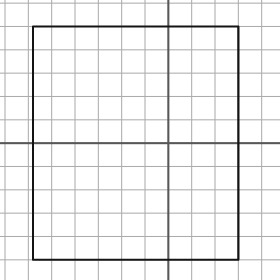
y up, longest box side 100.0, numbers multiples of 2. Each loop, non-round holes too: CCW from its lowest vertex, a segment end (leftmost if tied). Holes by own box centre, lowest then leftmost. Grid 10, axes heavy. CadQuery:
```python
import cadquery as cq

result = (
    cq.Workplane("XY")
    .moveTo(-58.0, -50.0)
    .lineTo(30.0, -50.0)
    .lineTo(30.0, 50.0)
    .lineTo(-58.0, 50.0)
    .close()
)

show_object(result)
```